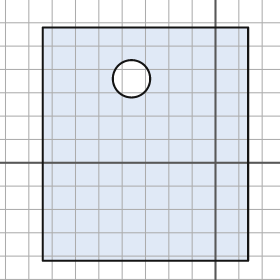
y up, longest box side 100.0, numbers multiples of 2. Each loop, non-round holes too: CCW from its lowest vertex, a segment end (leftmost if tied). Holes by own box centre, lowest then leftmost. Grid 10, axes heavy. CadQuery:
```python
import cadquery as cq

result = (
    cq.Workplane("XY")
    .moveTo(-74.0, -42.0)
    .lineTo(14.0, -42.0)
    .lineTo(14.0, 58.0)
    .lineTo(-74.0, 58.0)
    .close()
    .moveTo(-36.0, 36.0)
    .circle(8.0)
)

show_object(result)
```